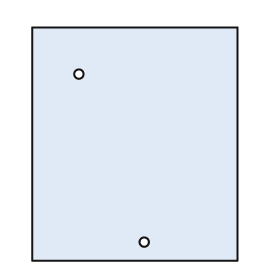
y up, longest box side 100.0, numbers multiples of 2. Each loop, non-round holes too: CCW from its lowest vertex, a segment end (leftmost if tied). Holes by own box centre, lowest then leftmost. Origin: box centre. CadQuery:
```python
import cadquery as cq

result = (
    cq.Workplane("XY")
    .moveTo(-44.0, -50.0)
    .lineTo(44.0, -50.0)
    .lineTo(44.0, 50.0)
    .lineTo(-44.0, 50.0)
    .close()
    .moveTo(4.0, -42.0)
    .circle(2.0)
    .moveTo(-24.0, 30.0)
    .circle(2.0)
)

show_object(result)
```